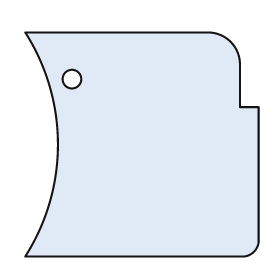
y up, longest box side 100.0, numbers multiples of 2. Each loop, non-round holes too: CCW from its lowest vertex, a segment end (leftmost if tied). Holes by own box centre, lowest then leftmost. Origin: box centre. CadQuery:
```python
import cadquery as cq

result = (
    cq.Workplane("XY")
    .moveTo(-50.0, -48.0)
    .lineTo(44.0, -48.0)
    .threePointArc((48.0, -46.0), (50.0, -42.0))
    .lineTo(50.0, 16.0)
    .lineTo(42.0, 16.0)
    .lineTo(42.0, 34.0)
    .threePointArc((38.0, 44.0), (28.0, 48.0))
    .lineTo(-50.0, 48.0)
    .threePointArc((-36.0, 0.0), (-50.0, -48.0))
    .close()
    .moveTo(-30.0, 28.0)
    .circle(4.0)
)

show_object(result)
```